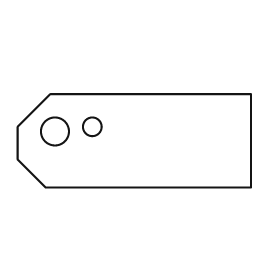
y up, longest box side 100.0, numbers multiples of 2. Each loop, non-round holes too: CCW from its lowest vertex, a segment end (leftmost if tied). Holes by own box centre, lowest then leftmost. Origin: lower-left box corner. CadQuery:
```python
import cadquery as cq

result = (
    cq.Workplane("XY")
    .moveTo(12.0, 0.0)
    .lineTo(100.0, 0.0)
    .lineTo(100.0, 40.0)
    .lineTo(14.0, 40.0)
    .lineTo(0.0, 26.0)
    .lineTo(0.0, 12.0)
    .close()
    .moveTo(16.0, 24.0)
    .circle(6.0)
    .moveTo(32.0, 26.0)
    .circle(4.0)
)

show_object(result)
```